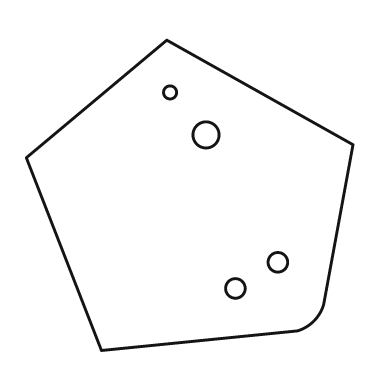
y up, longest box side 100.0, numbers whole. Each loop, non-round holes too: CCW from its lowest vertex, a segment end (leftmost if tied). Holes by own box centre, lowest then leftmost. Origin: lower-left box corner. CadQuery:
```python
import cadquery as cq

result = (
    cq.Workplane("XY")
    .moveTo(23.0, 0.0)
    .lineTo(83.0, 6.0)
    .threePointArc((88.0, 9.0), (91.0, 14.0))
    .lineTo(100.0, 63.0)
    .lineTo(43.0, 95.0)
    .lineTo(0.0, 59.0)
    .close()
    .moveTo(64.0, 19.0)
    .circle(3.0)
    .moveTo(77.0, 27.0)
    .circle(3.0)
    .moveTo(55.0, 66.0)
    .circle(4.0)
    .moveTo(44.0, 79.0)
    .circle(2.0)
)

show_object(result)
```